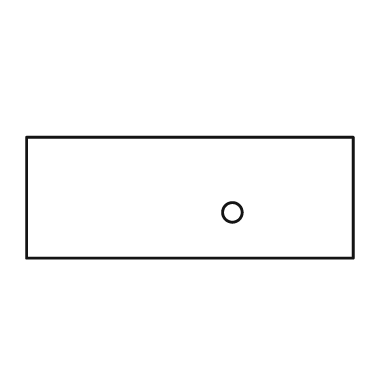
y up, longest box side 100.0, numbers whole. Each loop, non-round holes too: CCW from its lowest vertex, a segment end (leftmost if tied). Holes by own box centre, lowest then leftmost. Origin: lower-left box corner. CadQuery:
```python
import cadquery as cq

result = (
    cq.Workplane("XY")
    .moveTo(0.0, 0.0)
    .lineTo(100.0, 0.0)
    .lineTo(100.0, 37.0)
    .lineTo(0.0, 37.0)
    .close()
    .moveTo(63.0, 14.0)
    .circle(3.0)
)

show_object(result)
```